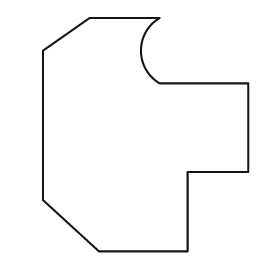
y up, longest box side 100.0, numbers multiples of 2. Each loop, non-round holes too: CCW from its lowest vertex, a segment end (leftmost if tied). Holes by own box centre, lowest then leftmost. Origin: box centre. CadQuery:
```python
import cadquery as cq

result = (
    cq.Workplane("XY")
    .moveTo(-20.0, -50.0)
    .lineTo(18.0, -50.0)
    .lineTo(18.0, -16.0)
    .lineTo(44.0, -16.0)
    .lineTo(44.0, 22.0)
    .lineTo(6.0, 22.0)
    .threePointArc((-2.0, 36.0), (6.0, 50.0))
    .lineTo(-24.0, 50.0)
    .lineTo(-44.0, 36.0)
    .lineTo(-44.0, -28.0)
    .close()
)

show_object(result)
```